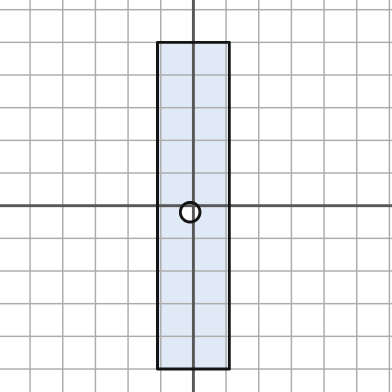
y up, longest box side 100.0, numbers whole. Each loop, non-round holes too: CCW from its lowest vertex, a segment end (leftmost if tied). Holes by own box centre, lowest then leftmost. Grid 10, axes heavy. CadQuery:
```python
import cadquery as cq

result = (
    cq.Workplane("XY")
    .moveTo(-11.0, -50.0)
    .lineTo(11.0, -50.0)
    .lineTo(11.0, 50.0)
    .lineTo(-11.0, 50.0)
    .close()
    .moveTo(-1.0, -2.0)
    .circle(3.0)
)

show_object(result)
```